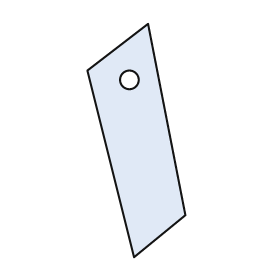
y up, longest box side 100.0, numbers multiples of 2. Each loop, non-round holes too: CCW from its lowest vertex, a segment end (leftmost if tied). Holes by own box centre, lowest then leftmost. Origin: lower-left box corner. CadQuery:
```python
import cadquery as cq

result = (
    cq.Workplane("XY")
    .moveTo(20.0, 0.0)
    .lineTo(42.0, 18.0)
    .lineTo(26.0, 100.0)
    .lineTo(0.0, 80.0)
    .close()
    .moveTo(18.0, 76.0)
    .circle(4.0)
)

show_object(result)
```